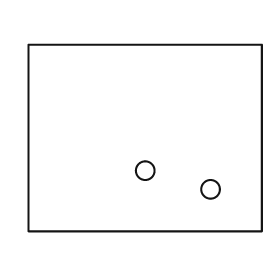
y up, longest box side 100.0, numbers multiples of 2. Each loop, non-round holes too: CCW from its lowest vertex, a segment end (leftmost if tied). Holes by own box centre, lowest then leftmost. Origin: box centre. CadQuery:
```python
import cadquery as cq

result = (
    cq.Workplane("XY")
    .moveTo(-50.0, -40.0)
    .lineTo(50.0, -40.0)
    .lineTo(50.0, 40.0)
    .lineTo(-50.0, 40.0)
    .close()
    .moveTo(28.0, -22.0)
    .circle(4.0)
    .moveTo(0.0, -14.0)
    .circle(4.0)
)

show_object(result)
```